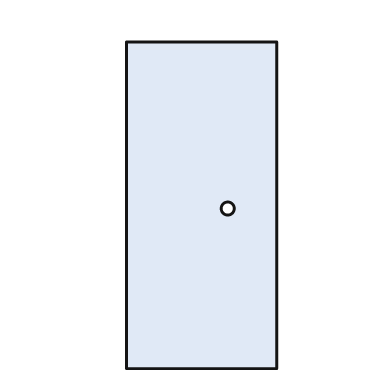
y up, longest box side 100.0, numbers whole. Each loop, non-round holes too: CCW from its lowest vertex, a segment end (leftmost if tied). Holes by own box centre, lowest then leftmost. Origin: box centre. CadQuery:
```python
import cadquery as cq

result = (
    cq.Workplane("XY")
    .moveTo(-23.0, -50.0)
    .lineTo(23.0, -50.0)
    .lineTo(23.0, 50.0)
    .lineTo(-23.0, 50.0)
    .close()
    .moveTo(8.0, -1.0)
    .circle(2.0)
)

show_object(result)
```